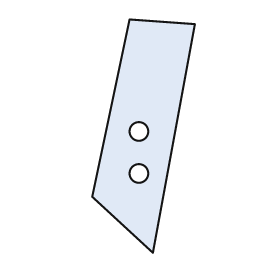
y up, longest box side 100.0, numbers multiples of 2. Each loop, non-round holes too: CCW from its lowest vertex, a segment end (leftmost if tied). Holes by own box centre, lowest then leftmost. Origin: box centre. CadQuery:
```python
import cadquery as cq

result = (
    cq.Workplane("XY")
    .moveTo(4.0, -50.0)
    .lineTo(22.0, 48.0)
    .lineTo(-6.0, 50.0)
    .lineTo(-22.0, -26.0)
    .close()
    .moveTo(-2.0, -16.0)
    .circle(4.0)
    .moveTo(-2.0, 2.0)
    .circle(4.0)
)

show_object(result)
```